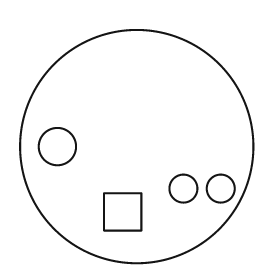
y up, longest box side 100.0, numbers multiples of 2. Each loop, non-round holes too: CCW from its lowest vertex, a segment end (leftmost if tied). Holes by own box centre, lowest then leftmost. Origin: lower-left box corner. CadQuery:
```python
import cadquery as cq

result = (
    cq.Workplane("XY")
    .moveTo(50.0, 50.0)
    .circle(50.0)
    .moveTo(36.0, 14.0)
    .lineTo(52.0, 14.0)
    .lineTo(52.0, 30.0)
    .lineTo(36.0, 30.0)
    .close()
    .moveTo(70.0, 32.0)
    .circle(6.0)
    .moveTo(86.0, 32.0)
    .circle(6.0)
    .moveTo(16.0, 50.0)
    .circle(8.0)
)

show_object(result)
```